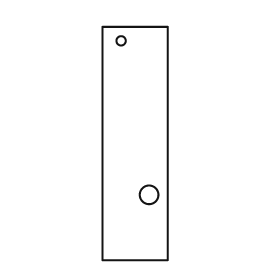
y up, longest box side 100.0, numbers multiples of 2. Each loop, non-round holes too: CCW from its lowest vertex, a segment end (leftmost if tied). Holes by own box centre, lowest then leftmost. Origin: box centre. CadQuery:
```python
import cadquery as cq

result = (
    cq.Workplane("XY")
    .moveTo(-14.0, -50.0)
    .lineTo(14.0, -50.0)
    .lineTo(14.0, 50.0)
    .lineTo(-14.0, 50.0)
    .close()
    .moveTo(6.0, -22.0)
    .circle(4.0)
    .moveTo(-6.0, 44.0)
    .circle(2.0)
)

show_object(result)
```